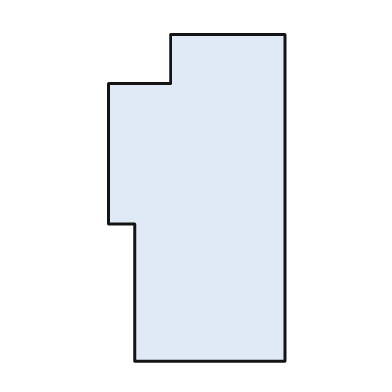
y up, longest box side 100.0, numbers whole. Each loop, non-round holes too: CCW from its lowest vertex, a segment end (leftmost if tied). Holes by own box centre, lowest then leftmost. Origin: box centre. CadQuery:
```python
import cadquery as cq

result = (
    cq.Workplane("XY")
    .moveTo(-19.0, -50.0)
    .lineTo(27.0, -50.0)
    .lineTo(27.0, 50.0)
    .lineTo(-8.0, 50.0)
    .lineTo(-8.0, 35.0)
    .lineTo(-27.0, 35.0)
    .lineTo(-27.0, -8.0)
    .lineTo(-19.0, -8.0)
    .close()
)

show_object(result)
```